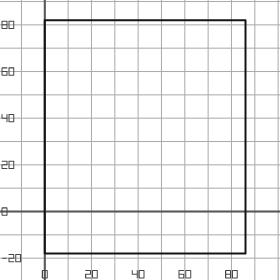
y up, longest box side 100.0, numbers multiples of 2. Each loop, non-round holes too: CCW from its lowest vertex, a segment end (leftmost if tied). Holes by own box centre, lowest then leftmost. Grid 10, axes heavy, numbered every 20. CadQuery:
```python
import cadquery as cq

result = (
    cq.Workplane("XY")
    .moveTo(0.0, -18.0)
    .lineTo(86.0, -18.0)
    .lineTo(86.0, 82.0)
    .lineTo(0.0, 82.0)
    .close()
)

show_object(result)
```